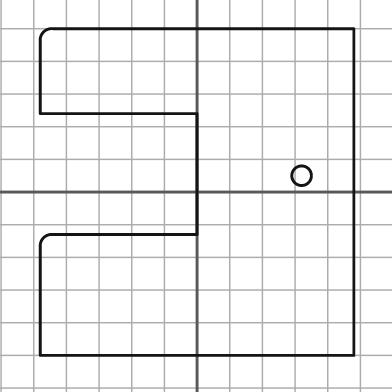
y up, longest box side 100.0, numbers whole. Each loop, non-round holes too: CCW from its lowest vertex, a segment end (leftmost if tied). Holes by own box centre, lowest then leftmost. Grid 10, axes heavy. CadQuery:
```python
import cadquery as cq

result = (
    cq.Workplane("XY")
    .moveTo(-48.0, -50.0)
    .lineTo(48.0, -50.0)
    .lineTo(48.0, 50.0)
    .lineTo(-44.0, 50.0)
    .threePointArc((-47.0, 49.0), (-48.0, 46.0))
    .lineTo(-48.0, 24.0)
    .lineTo(0.0, 24.0)
    .lineTo(0.0, -13.0)
    .lineTo(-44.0, -13.0)
    .threePointArc((-47.0, -14.0), (-48.0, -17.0))
    .close()
    .moveTo(32.0, 5.0)
    .circle(3.0)
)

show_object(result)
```